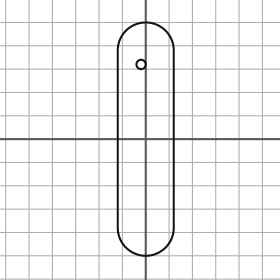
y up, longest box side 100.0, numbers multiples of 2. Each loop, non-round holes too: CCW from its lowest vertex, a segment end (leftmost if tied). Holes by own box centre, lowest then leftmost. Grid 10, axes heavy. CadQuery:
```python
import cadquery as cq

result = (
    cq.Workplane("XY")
    .moveTo(-12.0, -38.0)
    .threePointArc((0.0, -50.0), (12.0, -38.0))
    .lineTo(12.0, 38.0)
    .threePointArc((0.0, 50.0), (-12.0, 38.0))
    .close()
    .moveTo(-2.0, 32.0)
    .circle(2.0)
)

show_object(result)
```